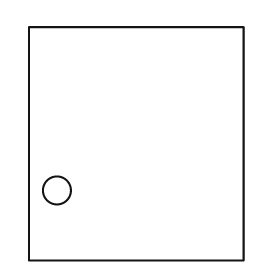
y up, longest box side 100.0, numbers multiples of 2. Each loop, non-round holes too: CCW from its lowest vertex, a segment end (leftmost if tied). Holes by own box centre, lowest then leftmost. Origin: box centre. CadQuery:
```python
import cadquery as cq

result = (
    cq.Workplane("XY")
    .moveTo(-46.0, -50.0)
    .lineTo(46.0, -50.0)
    .lineTo(46.0, 50.0)
    .lineTo(-46.0, 50.0)
    .close()
    .moveTo(-34.0, -20.0)
    .circle(6.0)
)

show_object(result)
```